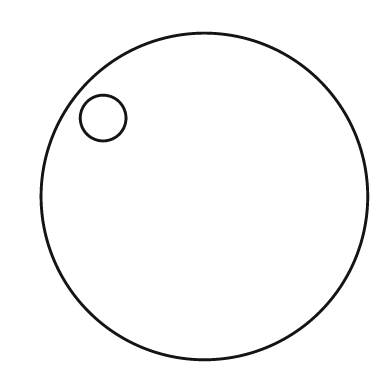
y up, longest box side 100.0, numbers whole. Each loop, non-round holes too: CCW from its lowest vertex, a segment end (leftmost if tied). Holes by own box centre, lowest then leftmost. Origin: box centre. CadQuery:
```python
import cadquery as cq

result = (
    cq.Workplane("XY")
    .moveTo(0.0, 0.0)
    .circle(50.0)
    .moveTo(-31.0, 24.0)
    .circle(7.0)
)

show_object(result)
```